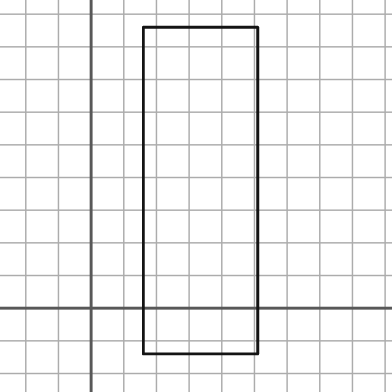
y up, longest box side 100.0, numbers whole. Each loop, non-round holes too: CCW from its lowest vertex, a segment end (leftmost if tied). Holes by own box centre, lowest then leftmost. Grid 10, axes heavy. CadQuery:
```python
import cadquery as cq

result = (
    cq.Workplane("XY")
    .moveTo(16.0, -14.0)
    .lineTo(51.0, -14.0)
    .lineTo(51.0, 86.0)
    .lineTo(16.0, 86.0)
    .close()
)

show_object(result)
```